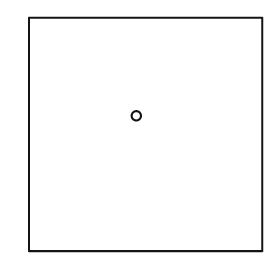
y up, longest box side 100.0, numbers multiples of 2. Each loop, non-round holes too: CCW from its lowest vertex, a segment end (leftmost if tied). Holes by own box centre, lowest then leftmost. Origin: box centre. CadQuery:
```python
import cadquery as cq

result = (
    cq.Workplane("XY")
    .moveTo(-50.0, -50.0)
    .lineTo(50.0, -50.0)
    .lineTo(50.0, 50.0)
    .lineTo(-50.0, 50.0)
    .close()
    .moveTo(-4.0, 8.0)
    .circle(2.0)
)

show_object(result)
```